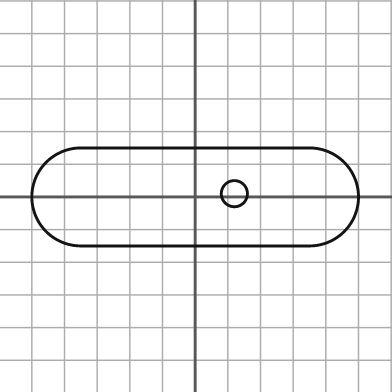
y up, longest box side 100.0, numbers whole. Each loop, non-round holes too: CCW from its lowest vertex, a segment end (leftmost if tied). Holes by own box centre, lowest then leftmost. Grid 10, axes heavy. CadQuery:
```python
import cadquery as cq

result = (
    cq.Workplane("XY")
    .moveTo(-35.0, -15.0)
    .lineTo(35.0, -15.0)
    .threePointArc((50.0, 0.0), (35.0, 15.0))
    .lineTo(-35.0, 15.0)
    .threePointArc((-50.0, 0.0), (-35.0, -15.0))
    .close()
    .moveTo(12.0, 1.0)
    .circle(4.0)
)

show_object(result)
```